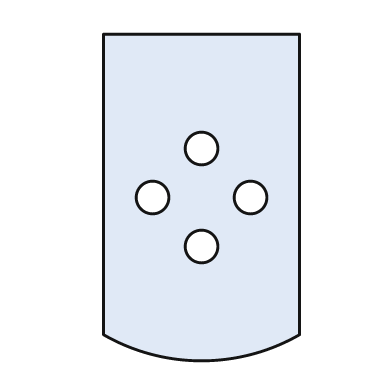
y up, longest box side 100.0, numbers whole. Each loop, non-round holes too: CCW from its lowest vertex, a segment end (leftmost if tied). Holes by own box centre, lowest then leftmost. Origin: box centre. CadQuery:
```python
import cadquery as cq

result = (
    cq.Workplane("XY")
    .moveTo(-30.0, -42.0)
    .threePointArc((0.0, -50.0), (30.0, -42.0))
    .lineTo(30.0, 50.0)
    .lineTo(-30.0, 50.0)
    .close()
    .moveTo(0.0, -15.0)
    .circle(5.0)
    .moveTo(-15.0, 0.0)
    .circle(5.0)
    .moveTo(15.0, 0.0)
    .circle(5.0)
    .moveTo(0.0, 15.0)
    .circle(5.0)
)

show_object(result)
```